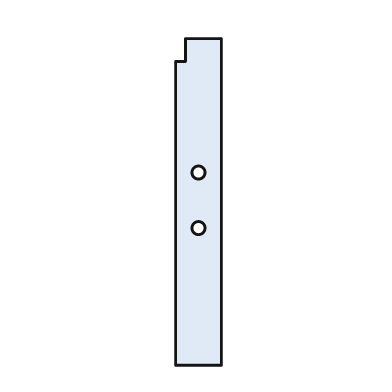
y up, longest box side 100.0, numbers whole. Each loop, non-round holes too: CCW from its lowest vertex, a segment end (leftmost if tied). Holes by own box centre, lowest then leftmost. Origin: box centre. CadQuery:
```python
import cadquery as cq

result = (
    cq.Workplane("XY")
    .moveTo(-7.0, -50.0)
    .lineTo(7.0, -50.0)
    .lineTo(7.0, 50.0)
    .lineTo(-4.0, 50.0)
    .lineTo(-4.0, 43.0)
    .lineTo(-7.0, 43.0)
    .close()
    .moveTo(0.0, -8.0)
    .circle(2.0)
    .moveTo(0.0, 9.0)
    .circle(2.0)
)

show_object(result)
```